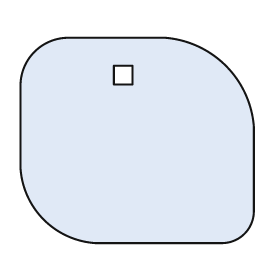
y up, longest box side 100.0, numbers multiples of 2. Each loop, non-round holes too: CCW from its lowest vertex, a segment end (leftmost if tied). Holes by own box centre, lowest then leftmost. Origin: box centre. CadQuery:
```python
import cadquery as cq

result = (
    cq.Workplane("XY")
    .moveTo(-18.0, -44.0)
    .lineTo(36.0, -44.0)
    .threePointArc((46.0, -40.0), (50.0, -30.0))
    .lineTo(50.0, 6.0)
    .threePointArc((38.0, 32.0), (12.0, 44.0))
    .lineTo(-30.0, 44.0)
    .threePointArc((-44.0, 38.0), (-50.0, 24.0))
    .lineTo(-50.0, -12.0)
    .threePointArc((-40.0, -34.0), (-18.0, -44.0))
    .close()
    .moveTo(-10.0, 24.0)
    .lineTo(-2.0, 24.0)
    .lineTo(-2.0, 32.0)
    .lineTo(-10.0, 32.0)
    .close()
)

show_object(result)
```